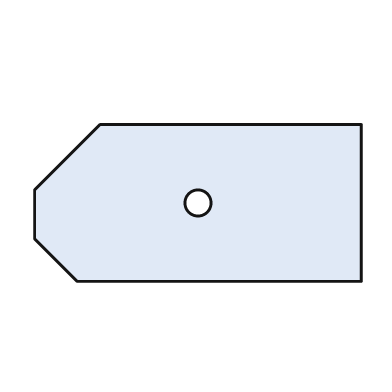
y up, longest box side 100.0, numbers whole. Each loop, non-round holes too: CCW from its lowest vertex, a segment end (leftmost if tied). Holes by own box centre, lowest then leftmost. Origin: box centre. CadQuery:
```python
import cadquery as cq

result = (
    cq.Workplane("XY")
    .moveTo(-37.0, -24.0)
    .lineTo(50.0, -24.0)
    .lineTo(50.0, 24.0)
    .lineTo(-30.0, 24.0)
    .lineTo(-50.0, 4.0)
    .lineTo(-50.0, -11.0)
    .close()
    .moveTo(0.0, 0.0)
    .circle(4.0)
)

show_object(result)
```